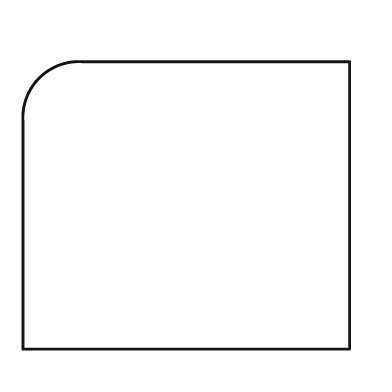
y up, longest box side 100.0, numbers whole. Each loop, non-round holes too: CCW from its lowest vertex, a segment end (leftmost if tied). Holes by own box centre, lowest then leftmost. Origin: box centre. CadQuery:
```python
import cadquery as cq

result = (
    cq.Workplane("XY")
    .moveTo(-50.0, -44.0)
    .lineTo(50.0, -44.0)
    .lineTo(50.0, 44.0)
    .lineTo(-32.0, 44.0)
    .threePointArc((-45.0, 39.0), (-50.0, 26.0))
    .close()
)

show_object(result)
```